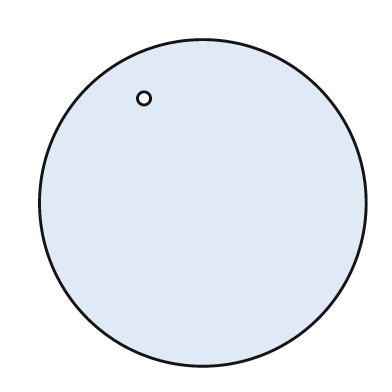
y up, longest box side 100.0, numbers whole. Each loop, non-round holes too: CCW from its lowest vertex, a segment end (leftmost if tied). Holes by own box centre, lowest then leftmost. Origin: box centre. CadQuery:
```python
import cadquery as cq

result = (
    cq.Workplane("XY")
    .moveTo(0.0, 0.0)
    .circle(50.0)
    .moveTo(-18.0, 32.0)
    .circle(2.0)
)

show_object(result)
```